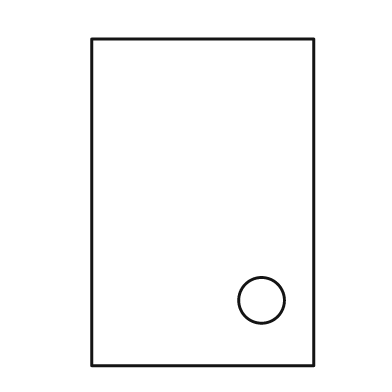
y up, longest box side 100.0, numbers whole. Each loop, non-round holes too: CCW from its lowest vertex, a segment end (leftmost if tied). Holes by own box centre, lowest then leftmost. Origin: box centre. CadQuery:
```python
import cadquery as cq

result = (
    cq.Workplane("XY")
    .moveTo(-34.0, -50.0)
    .lineTo(34.0, -50.0)
    .lineTo(34.0, 50.0)
    .lineTo(-34.0, 50.0)
    .close()
    .moveTo(18.0, -30.0)
    .circle(7.0)
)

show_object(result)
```